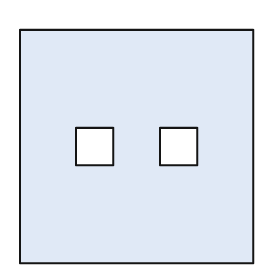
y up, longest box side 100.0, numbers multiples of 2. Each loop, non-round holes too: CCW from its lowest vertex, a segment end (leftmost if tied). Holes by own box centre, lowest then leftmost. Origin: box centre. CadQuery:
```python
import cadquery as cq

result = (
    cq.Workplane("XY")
    .moveTo(-50.0, -50.0)
    .lineTo(50.0, -50.0)
    .lineTo(50.0, 50.0)
    .lineTo(-50.0, 50.0)
    .close()
    .moveTo(-26.0, -8.0)
    .lineTo(-10.0, -8.0)
    .lineTo(-10.0, 8.0)
    .lineTo(-26.0, 8.0)
    .close()
    .moveTo(10.0, -8.0)
    .lineTo(26.0, -8.0)
    .lineTo(26.0, 8.0)
    .lineTo(10.0, 8.0)
    .close()
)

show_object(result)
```